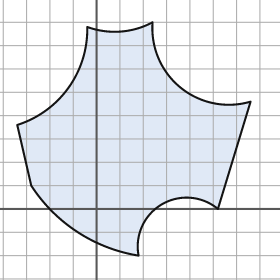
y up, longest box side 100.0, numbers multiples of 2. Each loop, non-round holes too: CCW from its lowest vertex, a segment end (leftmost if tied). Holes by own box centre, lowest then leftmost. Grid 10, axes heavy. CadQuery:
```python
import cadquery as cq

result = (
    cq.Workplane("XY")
    .moveTo(18.0, -20.0)
    .threePointArc((28.0, 2.0), (52.0, 0.0))
    .lineTo(66.0, 46.0)
    .threePointArc((36.0, 52.0), (24.0, 80.0))
    .threePointArc((10.0, 76.0), (-4.0, 78.0))
    .threePointArc((-12.0, 52.0), (-34.0, 36.0))
    .lineTo(-28.0, 10.0)
    .threePointArc((-8.0, -10.0), (18.0, -20.0))
    .close()
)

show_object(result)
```